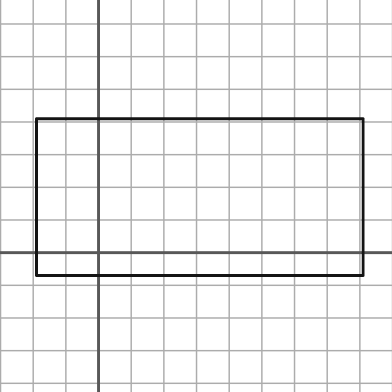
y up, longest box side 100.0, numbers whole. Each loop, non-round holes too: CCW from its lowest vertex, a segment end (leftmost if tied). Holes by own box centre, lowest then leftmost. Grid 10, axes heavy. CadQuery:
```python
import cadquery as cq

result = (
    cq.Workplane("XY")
    .moveTo(-19.0, -7.0)
    .lineTo(81.0, -7.0)
    .lineTo(81.0, 41.0)
    .lineTo(-19.0, 41.0)
    .close()
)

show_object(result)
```